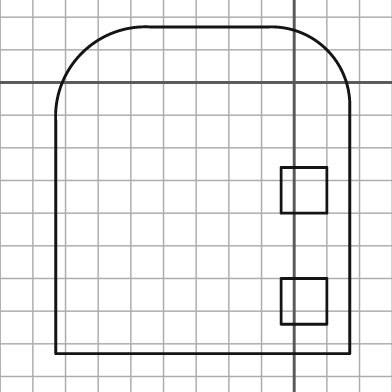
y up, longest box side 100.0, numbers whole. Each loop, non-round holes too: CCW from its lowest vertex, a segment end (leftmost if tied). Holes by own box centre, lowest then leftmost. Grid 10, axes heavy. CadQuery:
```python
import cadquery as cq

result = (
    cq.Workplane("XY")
    .moveTo(-73.0, -83.0)
    .lineTo(17.0, -83.0)
    .lineTo(17.0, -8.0)
    .threePointArc((10.0, 10.0), (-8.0, 17.0))
    .lineTo(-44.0, 17.0)
    .threePointArc((-65.0, 9.0), (-73.0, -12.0))
    .close()
    .moveTo(-4.0, -74.0)
    .lineTo(10.0, -74.0)
    .lineTo(10.0, -60.0)
    .lineTo(-4.0, -60.0)
    .close()
    .moveTo(-4.0, -40.0)
    .lineTo(10.0, -40.0)
    .lineTo(10.0, -26.0)
    .lineTo(-4.0, -26.0)
    .close()
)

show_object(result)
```